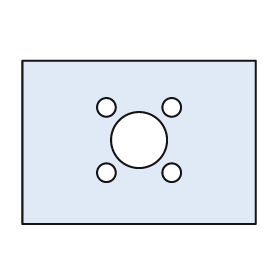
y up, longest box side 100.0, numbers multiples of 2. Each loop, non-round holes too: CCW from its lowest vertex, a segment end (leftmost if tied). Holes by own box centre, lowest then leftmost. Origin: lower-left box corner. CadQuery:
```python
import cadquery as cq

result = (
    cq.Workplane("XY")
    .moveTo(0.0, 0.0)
    .lineTo(100.0, 0.0)
    .lineTo(100.0, 70.0)
    .lineTo(0.0, 70.0)
    .close()
    .moveTo(36.0, 22.0)
    .circle(4.0)
    .moveTo(64.0, 22.0)
    .circle(4.0)
    .moveTo(50.0, 36.0)
    .circle(12.0)
    .moveTo(36.0, 50.0)
    .circle(4.0)
    .moveTo(64.0, 50.0)
    .circle(4.0)
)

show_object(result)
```